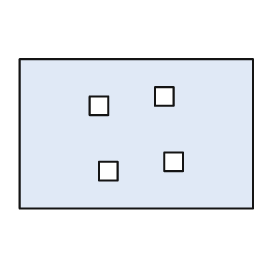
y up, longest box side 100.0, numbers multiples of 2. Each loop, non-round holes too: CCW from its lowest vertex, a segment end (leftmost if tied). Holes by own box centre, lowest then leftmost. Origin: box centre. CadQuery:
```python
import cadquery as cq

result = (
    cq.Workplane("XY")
    .moveTo(-50.0, -32.0)
    .lineTo(50.0, -32.0)
    .lineTo(50.0, 32.0)
    .lineTo(-50.0, 32.0)
    .close()
    .moveTo(-16.0, -20.0)
    .lineTo(-8.0, -20.0)
    .lineTo(-8.0, -12.0)
    .lineTo(-16.0, -12.0)
    .close()
    .moveTo(12.0, -16.0)
    .lineTo(20.0, -16.0)
    .lineTo(20.0, -8.0)
    .lineTo(12.0, -8.0)
    .close()
    .moveTo(-20.0, 8.0)
    .lineTo(-12.0, 8.0)
    .lineTo(-12.0, 16.0)
    .lineTo(-20.0, 16.0)
    .close()
    .moveTo(8.0, 12.0)
    .lineTo(16.0, 12.0)
    .lineTo(16.0, 20.0)
    .lineTo(8.0, 20.0)
    .close()
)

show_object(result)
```